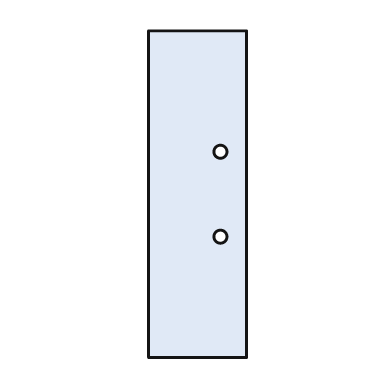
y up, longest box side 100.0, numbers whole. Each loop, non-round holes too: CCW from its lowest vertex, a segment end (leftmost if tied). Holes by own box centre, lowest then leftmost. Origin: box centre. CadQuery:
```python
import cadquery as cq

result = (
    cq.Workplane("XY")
    .moveTo(-15.0, -50.0)
    .lineTo(15.0, -50.0)
    .lineTo(15.0, 50.0)
    .lineTo(-15.0, 50.0)
    .close()
    .moveTo(7.0, -13.0)
    .circle(2.0)
    .moveTo(7.0, 13.0)
    .circle(2.0)
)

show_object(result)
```